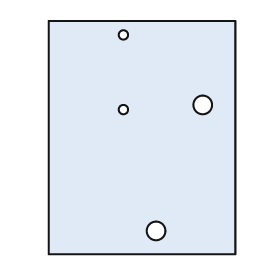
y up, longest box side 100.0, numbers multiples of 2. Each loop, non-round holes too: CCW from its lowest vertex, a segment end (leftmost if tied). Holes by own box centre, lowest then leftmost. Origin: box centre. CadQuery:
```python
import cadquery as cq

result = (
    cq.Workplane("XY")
    .moveTo(-40.0, -50.0)
    .lineTo(40.0, -50.0)
    .lineTo(40.0, 50.0)
    .lineTo(-40.0, 50.0)
    .close()
    .moveTo(6.0, -40.0)
    .circle(4.0)
    .moveTo(-8.0, 12.0)
    .circle(2.0)
    .moveTo(26.0, 14.0)
    .circle(4.0)
    .moveTo(-8.0, 44.0)
    .circle(2.0)
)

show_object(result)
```